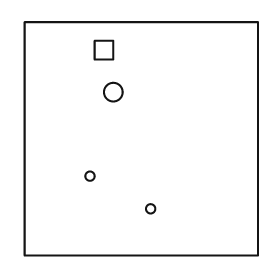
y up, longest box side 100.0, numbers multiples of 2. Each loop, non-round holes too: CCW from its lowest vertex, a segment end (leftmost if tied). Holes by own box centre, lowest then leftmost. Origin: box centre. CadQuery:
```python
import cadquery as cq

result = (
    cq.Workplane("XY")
    .moveTo(-50.0, -50.0)
    .lineTo(50.0, -50.0)
    .lineTo(50.0, 50.0)
    .lineTo(-50.0, 50.0)
    .close()
    .moveTo(4.0, -30.0)
    .circle(2.0)
    .moveTo(-22.0, -16.0)
    .circle(2.0)
    .moveTo(-12.0, 20.0)
    .circle(4.0)
    .moveTo(-20.0, 34.0)
    .lineTo(-12.0, 34.0)
    .lineTo(-12.0, 42.0)
    .lineTo(-20.0, 42.0)
    .close()
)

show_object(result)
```